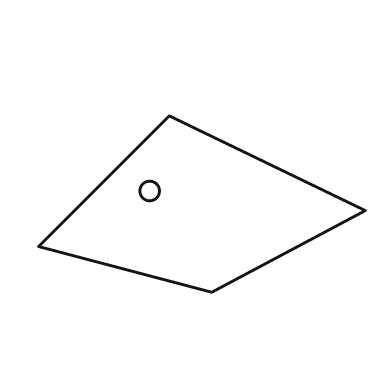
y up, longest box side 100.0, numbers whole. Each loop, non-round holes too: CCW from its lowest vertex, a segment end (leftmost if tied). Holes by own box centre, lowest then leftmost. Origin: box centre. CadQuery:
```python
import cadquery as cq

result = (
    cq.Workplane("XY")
    .moveTo(3.0, -27.0)
    .lineTo(50.0, -2.0)
    .lineTo(-10.0, 27.0)
    .lineTo(-50.0, -13.0)
    .close()
    .moveTo(-16.0, 4.0)
    .circle(3.0)
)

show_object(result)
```